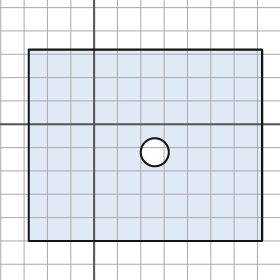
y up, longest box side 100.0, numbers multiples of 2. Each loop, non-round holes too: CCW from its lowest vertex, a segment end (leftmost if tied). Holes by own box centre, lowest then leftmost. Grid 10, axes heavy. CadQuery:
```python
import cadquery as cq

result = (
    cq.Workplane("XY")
    .moveTo(-28.0, -50.0)
    .lineTo(72.0, -50.0)
    .lineTo(72.0, 32.0)
    .lineTo(-28.0, 32.0)
    .close()
    .moveTo(26.0, -12.0)
    .circle(6.0)
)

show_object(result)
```